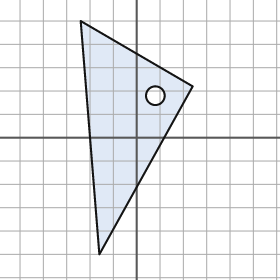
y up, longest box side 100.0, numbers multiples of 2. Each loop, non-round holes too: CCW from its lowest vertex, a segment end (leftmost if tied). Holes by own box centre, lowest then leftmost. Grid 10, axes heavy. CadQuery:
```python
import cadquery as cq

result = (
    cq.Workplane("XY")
    .moveTo(-16.0, -50.0)
    .lineTo(24.0, 22.0)
    .lineTo(-24.0, 50.0)
    .close()
    .moveTo(8.0, 18.0)
    .circle(4.0)
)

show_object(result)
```